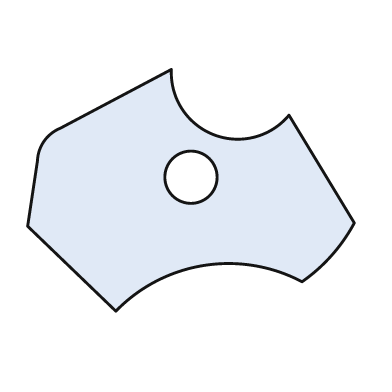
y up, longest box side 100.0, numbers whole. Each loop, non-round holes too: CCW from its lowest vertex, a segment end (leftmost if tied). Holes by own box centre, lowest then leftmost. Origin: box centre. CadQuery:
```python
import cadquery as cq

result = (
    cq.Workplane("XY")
    .moveTo(-23.0, -37.0)
    .threePointArc((4.0, -23.0), (34.0, -28.0))
    .threePointArc((43.0, -20.0), (50.0, -10.0))
    .lineTo(30.0, 23.0)
    .threePointArc((7.0, 17.0), (-6.0, 37.0))
    .lineTo(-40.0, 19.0)
    .threePointArc((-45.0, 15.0), (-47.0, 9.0))
    .lineTo(-50.0, -11.0)
    .close()
    .moveTo(0.0, 4.0)
    .circle(8.0)
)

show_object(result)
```